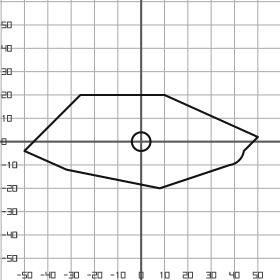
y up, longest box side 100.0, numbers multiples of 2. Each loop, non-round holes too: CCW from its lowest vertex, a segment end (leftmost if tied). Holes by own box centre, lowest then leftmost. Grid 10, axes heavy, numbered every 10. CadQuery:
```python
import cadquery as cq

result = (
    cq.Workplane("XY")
    .moveTo(8.0, -20.0)
    .lineTo(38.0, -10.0)
    .threePointArc((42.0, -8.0), (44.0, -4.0))
    .lineTo(50.0, 2.0)
    .lineTo(10.0, 20.0)
    .lineTo(-26.0, 20.0)
    .lineTo(-50.0, -4.0)
    .lineTo(-32.0, -12.0)
    .close()
    .moveTo(0.0, 0.0)
    .circle(4.0)
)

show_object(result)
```